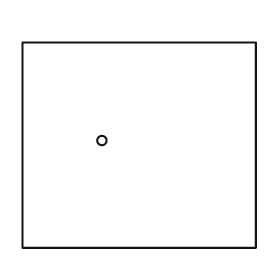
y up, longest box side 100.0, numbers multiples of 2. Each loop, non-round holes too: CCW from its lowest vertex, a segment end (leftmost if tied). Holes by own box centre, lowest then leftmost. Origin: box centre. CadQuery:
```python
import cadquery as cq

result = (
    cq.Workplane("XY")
    .moveTo(-50.0, -44.0)
    .lineTo(50.0, -44.0)
    .lineTo(50.0, 44.0)
    .lineTo(-50.0, 44.0)
    .close()
    .moveTo(-16.0, 2.0)
    .circle(2.0)
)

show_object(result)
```